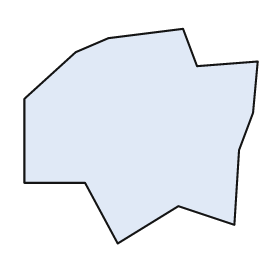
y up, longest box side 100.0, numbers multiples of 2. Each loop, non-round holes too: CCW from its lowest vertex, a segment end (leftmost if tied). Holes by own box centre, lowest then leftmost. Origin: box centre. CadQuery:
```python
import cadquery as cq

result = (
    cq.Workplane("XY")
    .moveTo(-10.0, -46.0)
    .lineTo(16.0, -30.0)
    .lineTo(40.0, -38.0)
    .lineTo(42.0, -6.0)
    .lineTo(48.0, 10.0)
    .lineTo(50.0, 32.0)
    .lineTo(24.0, 30.0)
    .lineTo(18.0, 46.0)
    .lineTo(-14.0, 42.0)
    .lineTo(-28.0, 36.0)
    .lineTo(-50.0, 16.0)
    .lineTo(-50.0, -20.0)
    .lineTo(-24.0, -20.0)
    .close()
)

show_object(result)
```